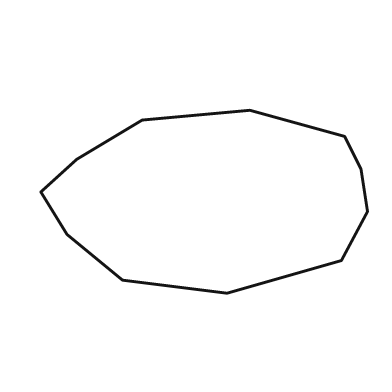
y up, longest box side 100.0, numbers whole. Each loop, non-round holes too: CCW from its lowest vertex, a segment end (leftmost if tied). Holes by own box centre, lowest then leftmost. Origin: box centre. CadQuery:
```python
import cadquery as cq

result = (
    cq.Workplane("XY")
    .moveTo(7.0, -28.0)
    .lineTo(42.0, -18.0)
    .lineTo(50.0, -3.0)
    .lineTo(48.0, 10.0)
    .lineTo(43.0, 20.0)
    .lineTo(14.0, 28.0)
    .lineTo(-19.0, 25.0)
    .lineTo(-39.0, 13.0)
    .lineTo(-50.0, 3.0)
    .lineTo(-42.0, -10.0)
    .lineTo(-25.0, -24.0)
    .close()
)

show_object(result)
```